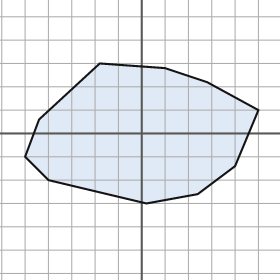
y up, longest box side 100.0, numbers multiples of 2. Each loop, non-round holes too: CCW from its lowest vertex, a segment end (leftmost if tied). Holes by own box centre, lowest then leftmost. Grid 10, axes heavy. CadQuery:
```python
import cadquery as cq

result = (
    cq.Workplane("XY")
    .moveTo(2.0, -30.0)
    .lineTo(24.0, -26.0)
    .lineTo(40.0, -14.0)
    .lineTo(50.0, 10.0)
    .lineTo(28.0, 22.0)
    .lineTo(10.0, 28.0)
    .lineTo(-18.0, 30.0)
    .lineTo(-44.0, 6.0)
    .lineTo(-50.0, -10.0)
    .lineTo(-40.0, -20.0)
    .close()
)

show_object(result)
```